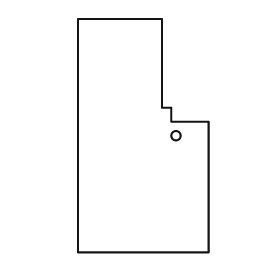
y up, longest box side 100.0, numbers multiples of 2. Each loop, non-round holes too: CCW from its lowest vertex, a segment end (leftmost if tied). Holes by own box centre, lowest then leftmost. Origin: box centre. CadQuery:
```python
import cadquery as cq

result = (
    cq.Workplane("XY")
    .moveTo(-28.0, -50.0)
    .lineTo(28.0, -50.0)
    .lineTo(28.0, 6.0)
    .lineTo(12.0, 6.0)
    .lineTo(12.0, 12.0)
    .lineTo(8.0, 12.0)
    .lineTo(8.0, 50.0)
    .lineTo(-28.0, 50.0)
    .close()
    .moveTo(14.0, 0.0)
    .circle(2.0)
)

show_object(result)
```